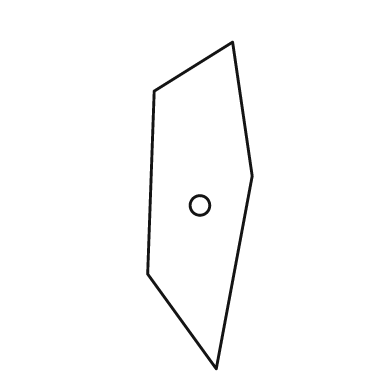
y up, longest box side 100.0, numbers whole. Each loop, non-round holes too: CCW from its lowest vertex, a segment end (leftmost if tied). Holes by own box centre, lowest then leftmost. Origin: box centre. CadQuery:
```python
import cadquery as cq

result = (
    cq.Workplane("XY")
    .moveTo(5.0, -50.0)
    .lineTo(16.0, 9.0)
    .lineTo(10.0, 50.0)
    .lineTo(-14.0, 35.0)
    .lineTo(-16.0, -21.0)
    .close()
    .moveTo(0.0, 0.0)
    .circle(3.0)
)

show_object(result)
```